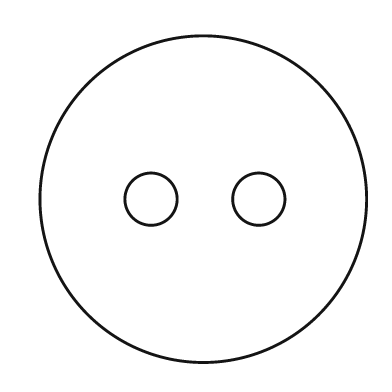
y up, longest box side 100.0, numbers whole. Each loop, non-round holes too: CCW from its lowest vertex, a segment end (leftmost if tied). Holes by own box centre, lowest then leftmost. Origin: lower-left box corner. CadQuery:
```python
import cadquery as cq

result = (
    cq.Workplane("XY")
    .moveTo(50.0, 50.0)
    .circle(50.0)
    .moveTo(34.0, 50.0)
    .circle(8.0)
    .moveTo(67.0, 50.0)
    .circle(8.0)
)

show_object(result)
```